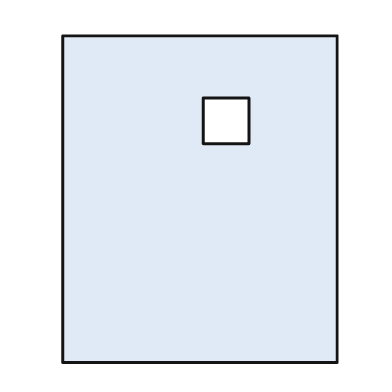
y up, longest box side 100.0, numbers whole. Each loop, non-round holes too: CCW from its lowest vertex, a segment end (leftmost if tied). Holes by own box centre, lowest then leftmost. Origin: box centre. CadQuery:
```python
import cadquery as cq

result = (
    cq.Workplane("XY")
    .moveTo(-42.0, -50.0)
    .lineTo(42.0, -50.0)
    .lineTo(42.0, 50.0)
    .lineTo(-42.0, 50.0)
    .close()
    .moveTo(1.0, 17.0)
    .lineTo(15.0, 17.0)
    .lineTo(15.0, 31.0)
    .lineTo(1.0, 31.0)
    .close()
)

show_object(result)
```